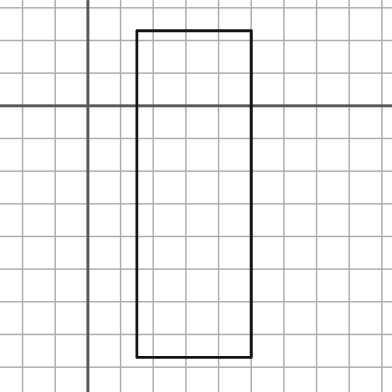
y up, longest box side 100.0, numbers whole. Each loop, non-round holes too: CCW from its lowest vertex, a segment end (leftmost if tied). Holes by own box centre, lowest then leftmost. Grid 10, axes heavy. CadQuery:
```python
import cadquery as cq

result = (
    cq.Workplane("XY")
    .moveTo(15.0, -77.0)
    .lineTo(50.0, -77.0)
    .lineTo(50.0, 23.0)
    .lineTo(15.0, 23.0)
    .close()
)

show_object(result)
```